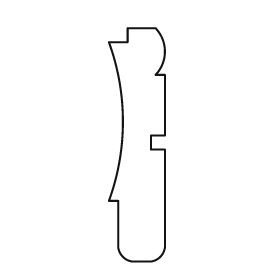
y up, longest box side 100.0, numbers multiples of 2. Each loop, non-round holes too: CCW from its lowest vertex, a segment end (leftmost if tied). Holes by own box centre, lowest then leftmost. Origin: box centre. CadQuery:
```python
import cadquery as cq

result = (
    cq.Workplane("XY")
    .moveTo(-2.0, -50.0)
    .lineTo(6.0, -50.0)
    .threePointArc((10.0, -48.0), (12.0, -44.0))
    .lineTo(12.0, -2.0)
    .lineTo(6.0, -2.0)
    .lineTo(6.0, 4.0)
    .lineTo(12.0, 4.0)
    .lineTo(12.0, 30.0)
    .lineTo(8.0, 30.0)
    .threePointArc((12.0, 40.0), (8.0, 50.0))
    .lineTo(-4.0, 50.0)
    .lineTo(-4.0, 44.0)
    .lineTo(-12.0, 44.0)
    .threePointArc((-6.0, 10.0), (-12.0, -24.0))
    .lineTo(-8.0, -24.0)
    .lineTo(-8.0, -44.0)
    .threePointArc((-6.0, -48.0), (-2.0, -50.0))
    .close()
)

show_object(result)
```